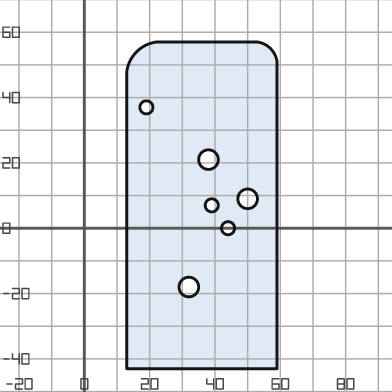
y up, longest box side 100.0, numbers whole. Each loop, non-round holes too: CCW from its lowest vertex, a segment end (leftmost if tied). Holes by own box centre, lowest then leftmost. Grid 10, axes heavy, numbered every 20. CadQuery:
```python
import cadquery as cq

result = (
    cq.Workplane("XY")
    .moveTo(13.0, -43.0)
    .lineTo(59.0, -43.0)
    .lineTo(59.0, 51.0)
    .threePointArc((57.0, 55.0), (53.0, 57.0))
    .lineTo(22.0, 57.0)
    .threePointArc((16.0, 54.0), (13.0, 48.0))
    .close()
    .moveTo(32.0, -18.0)
    .circle(3.0)
    .moveTo(44.0, 0.0)
    .circle(2.0)
    .moveTo(39.0, 7.0)
    .circle(2.0)
    .moveTo(50.0, 9.0)
    .circle(3.0)
    .moveTo(38.0, 21.0)
    .circle(3.0)
    .moveTo(19.0, 37.0)
    .circle(2.0)
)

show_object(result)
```